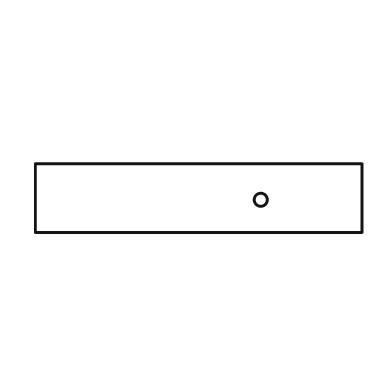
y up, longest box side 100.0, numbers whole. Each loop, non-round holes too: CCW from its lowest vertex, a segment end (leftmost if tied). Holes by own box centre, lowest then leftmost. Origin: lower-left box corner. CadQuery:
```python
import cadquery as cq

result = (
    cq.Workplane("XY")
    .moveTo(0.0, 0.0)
    .lineTo(100.0, 0.0)
    .lineTo(100.0, 21.0)
    .lineTo(0.0, 21.0)
    .close()
    .moveTo(69.0, 10.0)
    .circle(2.0)
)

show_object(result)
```